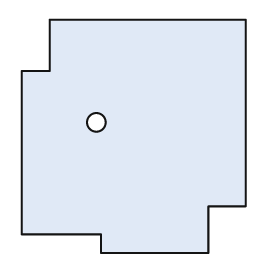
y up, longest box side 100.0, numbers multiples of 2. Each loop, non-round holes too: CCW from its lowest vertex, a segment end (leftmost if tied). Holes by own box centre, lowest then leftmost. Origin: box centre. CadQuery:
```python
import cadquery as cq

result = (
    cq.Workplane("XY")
    .moveTo(-14.0, -50.0)
    .lineTo(32.0, -50.0)
    .lineTo(32.0, -30.0)
    .lineTo(48.0, -30.0)
    .lineTo(48.0, 50.0)
    .lineTo(-36.0, 50.0)
    .lineTo(-36.0, 28.0)
    .lineTo(-48.0, 28.0)
    .lineTo(-48.0, -42.0)
    .lineTo(-14.0, -42.0)
    .close()
    .moveTo(-16.0, 6.0)
    .circle(4.0)
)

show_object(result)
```